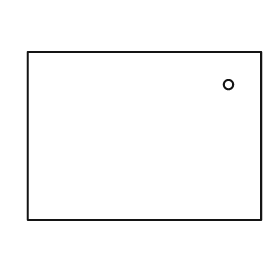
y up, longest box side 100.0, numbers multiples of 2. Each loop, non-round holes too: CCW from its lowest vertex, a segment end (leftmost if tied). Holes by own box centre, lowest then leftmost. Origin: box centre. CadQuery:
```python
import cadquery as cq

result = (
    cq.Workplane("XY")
    .moveTo(-50.0, -36.0)
    .lineTo(50.0, -36.0)
    .lineTo(50.0, 36.0)
    .lineTo(-50.0, 36.0)
    .close()
    .moveTo(36.0, 22.0)
    .circle(2.0)
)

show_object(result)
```